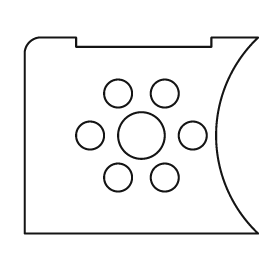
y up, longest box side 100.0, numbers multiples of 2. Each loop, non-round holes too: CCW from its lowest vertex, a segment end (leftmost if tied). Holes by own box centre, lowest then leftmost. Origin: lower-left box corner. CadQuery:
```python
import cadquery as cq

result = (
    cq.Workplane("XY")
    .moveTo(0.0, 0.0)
    .lineTo(100.0, 0.0)
    .threePointArc((82.0, 42.0), (100.0, 84.0))
    .lineTo(80.0, 84.0)
    .lineTo(80.0, 80.0)
    .lineTo(22.0, 80.0)
    .lineTo(22.0, 84.0)
    .lineTo(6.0, 84.0)
    .threePointArc((2.0, 82.0), (0.0, 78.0))
    .close()
    .moveTo(40.0, 24.0)
    .circle(6.0)
    .moveTo(60.0, 24.0)
    .circle(6.0)
    .moveTo(28.0, 42.0)
    .circle(6.0)
    .moveTo(50.0, 42.0)
    .circle(10.0)
    .moveTo(72.0, 42.0)
    .circle(6.0)
    .moveTo(40.0, 60.0)
    .circle(6.0)
    .moveTo(60.0, 60.0)
    .circle(6.0)
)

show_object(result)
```